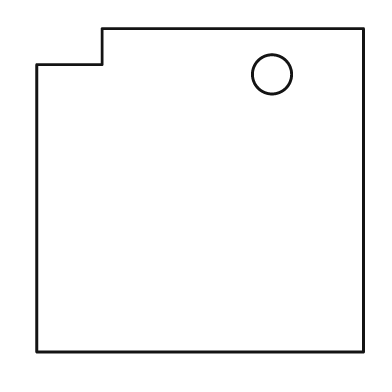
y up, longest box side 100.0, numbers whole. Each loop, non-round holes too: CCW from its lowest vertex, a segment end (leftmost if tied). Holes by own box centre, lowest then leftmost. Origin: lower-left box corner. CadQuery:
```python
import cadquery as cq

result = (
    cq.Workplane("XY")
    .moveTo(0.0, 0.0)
    .lineTo(100.0, 0.0)
    .lineTo(100.0, 99.0)
    .lineTo(20.0, 99.0)
    .lineTo(20.0, 88.0)
    .lineTo(0.0, 88.0)
    .close()
    .moveTo(72.0, 85.0)
    .circle(6.0)
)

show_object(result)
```